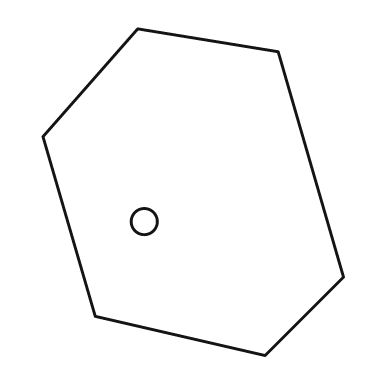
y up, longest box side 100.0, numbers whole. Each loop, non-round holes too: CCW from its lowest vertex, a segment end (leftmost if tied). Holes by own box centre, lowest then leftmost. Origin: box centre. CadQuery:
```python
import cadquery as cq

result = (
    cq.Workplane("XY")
    .moveTo(22.0, -50.0)
    .lineTo(46.0, -26.0)
    .lineTo(26.0, 43.0)
    .lineTo(-17.0, 50.0)
    .lineTo(-46.0, 17.0)
    .lineTo(-30.0, -38.0)
    .close()
    .moveTo(-15.0, -9.0)
    .circle(4.0)
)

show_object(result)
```